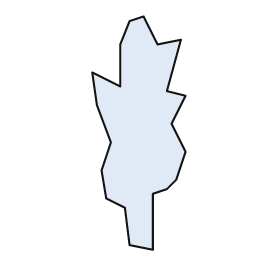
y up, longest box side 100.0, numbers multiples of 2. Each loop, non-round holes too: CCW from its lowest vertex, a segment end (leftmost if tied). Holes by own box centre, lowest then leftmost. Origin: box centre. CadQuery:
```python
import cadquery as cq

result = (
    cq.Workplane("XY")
    .moveTo(6.0, -50.0)
    .lineTo(6.0, -26.0)
    .lineTo(12.0, -24.0)
    .lineTo(16.0, -20.0)
    .lineTo(20.0, -8.0)
    .lineTo(14.0, 4.0)
    .lineTo(20.0, 16.0)
    .lineTo(12.0, 18.0)
    .lineTo(18.0, 40.0)
    .lineTo(8.0, 38.0)
    .lineTo(2.0, 50.0)
    .lineTo(-4.0, 48.0)
    .lineTo(-8.0, 38.0)
    .lineTo(-8.0, 20.0)
    .lineTo(-20.0, 26.0)
    .lineTo(-18.0, 12.0)
    .lineTo(-12.0, -4.0)
    .lineTo(-16.0, -16.0)
    .lineTo(-14.0, -28.0)
    .lineTo(-6.0, -32.0)
    .lineTo(-4.0, -48.0)
    .close()
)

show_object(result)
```